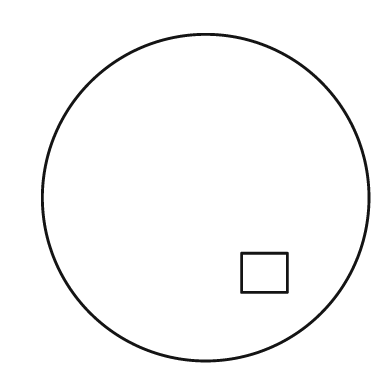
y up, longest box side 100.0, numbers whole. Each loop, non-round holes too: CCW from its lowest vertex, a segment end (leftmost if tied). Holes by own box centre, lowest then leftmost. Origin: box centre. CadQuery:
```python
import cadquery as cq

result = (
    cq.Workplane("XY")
    .moveTo(0.0, 0.0)
    .circle(50.0)
    .moveTo(11.0, -29.0)
    .lineTo(25.0, -29.0)
    .lineTo(25.0, -17.0)
    .lineTo(11.0, -17.0)
    .close()
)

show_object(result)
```